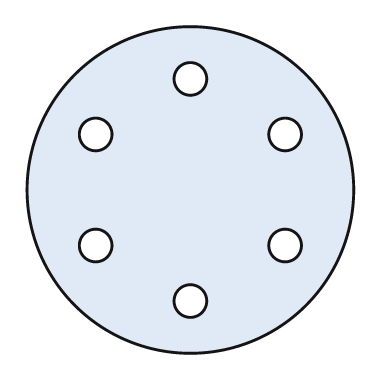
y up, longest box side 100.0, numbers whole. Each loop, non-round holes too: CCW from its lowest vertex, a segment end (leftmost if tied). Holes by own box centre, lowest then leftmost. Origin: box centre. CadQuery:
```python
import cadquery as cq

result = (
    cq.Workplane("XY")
    .moveTo(0.0, 0.0)
    .circle(50.0)
    .moveTo(0.0, -34.0)
    .circle(5.0)
    .moveTo(-29.0, -17.0)
    .circle(5.0)
    .moveTo(29.0, -17.0)
    .circle(5.0)
    .moveTo(-29.0, 17.0)
    .circle(5.0)
    .moveTo(29.0, 17.0)
    .circle(5.0)
    .moveTo(0.0, 34.0)
    .circle(5.0)
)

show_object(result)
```